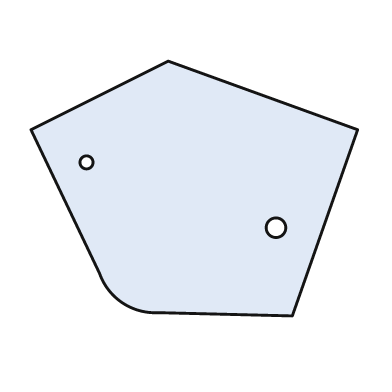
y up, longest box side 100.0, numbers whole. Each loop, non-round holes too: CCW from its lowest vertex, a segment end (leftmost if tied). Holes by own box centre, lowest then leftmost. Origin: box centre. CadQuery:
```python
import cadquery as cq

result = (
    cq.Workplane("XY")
    .moveTo(30.0, -39.0)
    .lineTo(50.0, 18.0)
    .lineTo(-8.0, 39.0)
    .lineTo(-50.0, 18.0)
    .lineTo(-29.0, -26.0)
    .threePointArc((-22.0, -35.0), (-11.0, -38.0))
    .close()
    .moveTo(25.0, -12.0)
    .circle(3.0)
    .moveTo(-33.0, 8.0)
    .circle(2.0)
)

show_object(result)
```